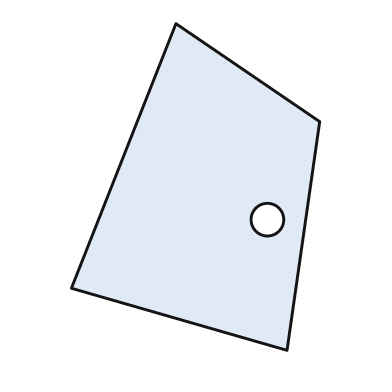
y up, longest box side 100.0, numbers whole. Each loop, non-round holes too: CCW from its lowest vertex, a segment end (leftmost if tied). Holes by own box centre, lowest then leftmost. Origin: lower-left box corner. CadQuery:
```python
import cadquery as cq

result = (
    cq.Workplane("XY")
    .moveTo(66.0, 0.0)
    .lineTo(76.0, 70.0)
    .lineTo(32.0, 100.0)
    .lineTo(0.0, 19.0)
    .close()
    .moveTo(60.0, 40.0)
    .circle(5.0)
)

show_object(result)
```